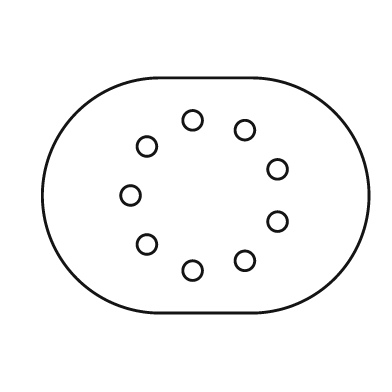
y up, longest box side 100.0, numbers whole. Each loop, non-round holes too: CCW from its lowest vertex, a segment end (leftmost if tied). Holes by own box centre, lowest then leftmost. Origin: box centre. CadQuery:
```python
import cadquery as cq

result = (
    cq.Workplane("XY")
    .moveTo(-14.0, -36.0)
    .lineTo(14.0, -36.0)
    .threePointArc((50.0, 0.0), (14.0, 36.0))
    .lineTo(-14.0, 36.0)
    .threePointArc((-50.0, 0.0), (-14.0, -36.0))
    .close()
    .moveTo(-4.0, -23.0)
    .circle(3.0)
    .moveTo(12.0, -20.0)
    .circle(3.0)
    .moveTo(-18.0, -15.0)
    .circle(3.0)
    .moveTo(22.0, -8.0)
    .circle(3.0)
    .moveTo(-23.0, 0.0)
    .circle(3.0)
    .moveTo(22.0, 8.0)
    .circle(3.0)
    .moveTo(-18.0, 15.0)
    .circle(3.0)
    .moveTo(12.0, 20.0)
    .circle(3.0)
    .moveTo(-4.0, 23.0)
    .circle(3.0)
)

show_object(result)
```